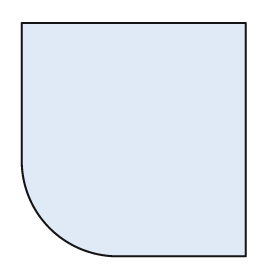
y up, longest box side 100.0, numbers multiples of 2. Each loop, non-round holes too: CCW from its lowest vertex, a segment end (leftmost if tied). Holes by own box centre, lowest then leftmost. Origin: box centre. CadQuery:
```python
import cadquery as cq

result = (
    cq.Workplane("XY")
    .moveTo(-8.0, -50.0)
    .lineTo(48.0, -50.0)
    .lineTo(48.0, 50.0)
    .lineTo(-48.0, 50.0)
    .lineTo(-48.0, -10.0)
    .threePointArc((-36.0, -38.0), (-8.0, -50.0))
    .close()
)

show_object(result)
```